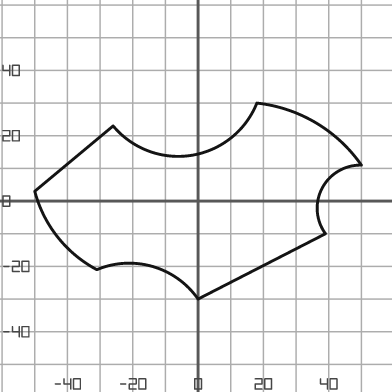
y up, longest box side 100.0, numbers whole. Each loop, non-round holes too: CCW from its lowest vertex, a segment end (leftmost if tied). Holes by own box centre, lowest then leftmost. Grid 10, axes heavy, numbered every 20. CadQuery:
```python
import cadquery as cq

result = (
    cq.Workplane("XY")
    .moveTo(0.0, -30.0)
    .lineTo(39.0, -10.0)
    .threePointArc((38.0, 4.0), (50.0, 11.0))
    .threePointArc((36.0, 24.0), (18.0, 30.0))
    .threePointArc((-2.0, 14.0), (-26.0, 23.0))
    .lineTo(-50.0, 3.0)
    .threePointArc((-43.0, -11.0), (-31.0, -21.0))
    .threePointArc((-14.0, -20.0), (0.0, -30.0))
    .close()
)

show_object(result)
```